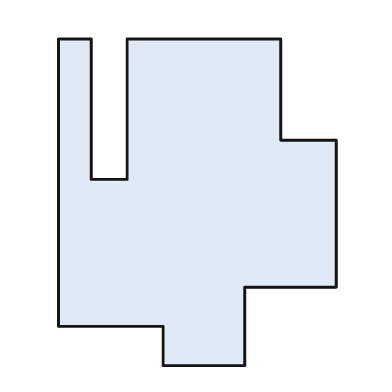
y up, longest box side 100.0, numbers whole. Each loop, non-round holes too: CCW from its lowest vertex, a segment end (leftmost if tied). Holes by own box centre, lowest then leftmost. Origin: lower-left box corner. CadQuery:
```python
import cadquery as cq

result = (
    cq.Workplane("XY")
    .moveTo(32.0, 0.0)
    .lineTo(57.0, 0.0)
    .lineTo(57.0, 24.0)
    .lineTo(85.0, 24.0)
    .lineTo(85.0, 69.0)
    .lineTo(68.0, 69.0)
    .lineTo(68.0, 100.0)
    .lineTo(21.0, 100.0)
    .lineTo(21.0, 57.0)
    .lineTo(10.0, 57.0)
    .lineTo(10.0, 100.0)
    .lineTo(0.0, 100.0)
    .lineTo(0.0, 12.0)
    .lineTo(32.0, 12.0)
    .close()
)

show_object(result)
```